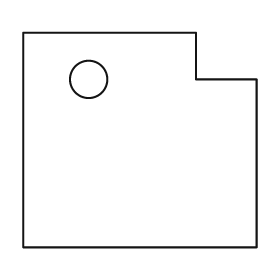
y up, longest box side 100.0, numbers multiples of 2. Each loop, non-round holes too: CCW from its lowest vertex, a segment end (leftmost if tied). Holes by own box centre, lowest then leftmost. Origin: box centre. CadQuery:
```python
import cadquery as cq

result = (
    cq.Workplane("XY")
    .moveTo(-50.0, -46.0)
    .lineTo(50.0, -46.0)
    .lineTo(50.0, 26.0)
    .lineTo(24.0, 26.0)
    .lineTo(24.0, 46.0)
    .lineTo(-50.0, 46.0)
    .close()
    .moveTo(-22.0, 26.0)
    .circle(8.0)
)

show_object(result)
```